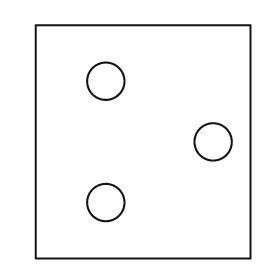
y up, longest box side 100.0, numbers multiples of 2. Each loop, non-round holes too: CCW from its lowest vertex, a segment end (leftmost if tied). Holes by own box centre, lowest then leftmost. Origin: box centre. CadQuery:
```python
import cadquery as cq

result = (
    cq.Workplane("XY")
    .moveTo(-46.0, -50.0)
    .lineTo(46.0, -50.0)
    .lineTo(46.0, 50.0)
    .lineTo(-46.0, 50.0)
    .close()
    .moveTo(-16.0, -26.0)
    .circle(8.0)
    .moveTo(30.0, 0.0)
    .circle(8.0)
    .moveTo(-16.0, 26.0)
    .circle(8.0)
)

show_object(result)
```